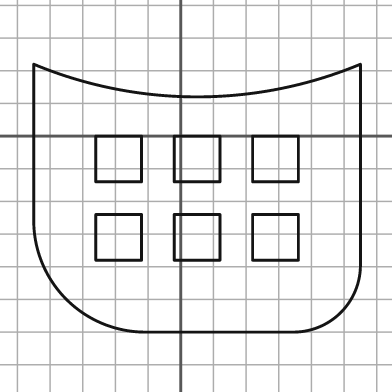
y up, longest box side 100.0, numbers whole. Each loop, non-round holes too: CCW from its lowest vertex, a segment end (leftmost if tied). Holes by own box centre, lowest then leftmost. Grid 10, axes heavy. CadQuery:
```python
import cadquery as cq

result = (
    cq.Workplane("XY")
    .moveTo(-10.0, -60.0)
    .lineTo(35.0, -60.0)
    .threePointArc((49.0, -54.0), (55.0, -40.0))
    .lineTo(55.0, 22.0)
    .threePointArc((5.0, 12.0), (-45.0, 22.0))
    .lineTo(-45.0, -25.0)
    .threePointArc((-35.0, -50.0), (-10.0, -60.0))
    .close()
    .moveTo(-26.0, -38.0)
    .lineTo(-12.0, -38.0)
    .lineTo(-12.0, -24.0)
    .lineTo(-26.0, -24.0)
    .close()
    .moveTo(-2.0, -38.0)
    .lineTo(12.0, -38.0)
    .lineTo(12.0, -24.0)
    .lineTo(-2.0, -24.0)
    .close()
    .moveTo(22.0, -38.0)
    .lineTo(36.0, -38.0)
    .lineTo(36.0, -24.0)
    .lineTo(22.0, -24.0)
    .close()
    .moveTo(-26.0, -14.0)
    .lineTo(-12.0, -14.0)
    .lineTo(-12.0, 0.0)
    .lineTo(-26.0, 0.0)
    .close()
    .moveTo(-2.0, -14.0)
    .lineTo(12.0, -14.0)
    .lineTo(12.0, 0.0)
    .lineTo(-2.0, 0.0)
    .close()
    .moveTo(22.0, -14.0)
    .lineTo(36.0, -14.0)
    .lineTo(36.0, 0.0)
    .lineTo(22.0, 0.0)
    .close()
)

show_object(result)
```